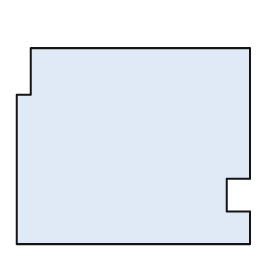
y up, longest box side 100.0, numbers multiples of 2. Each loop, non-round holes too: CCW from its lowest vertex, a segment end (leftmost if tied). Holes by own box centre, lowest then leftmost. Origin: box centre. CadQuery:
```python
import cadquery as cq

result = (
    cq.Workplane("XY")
    .moveTo(-50.0, -42.0)
    .lineTo(50.0, -42.0)
    .lineTo(50.0, -28.0)
    .lineTo(40.0, -28.0)
    .lineTo(40.0, -14.0)
    .lineTo(50.0, -14.0)
    .lineTo(50.0, 42.0)
    .lineTo(-44.0, 42.0)
    .lineTo(-44.0, 22.0)
    .lineTo(-50.0, 22.0)
    .close()
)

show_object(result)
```